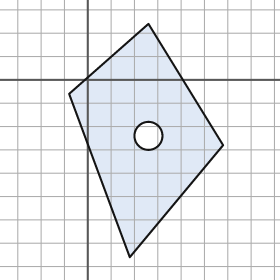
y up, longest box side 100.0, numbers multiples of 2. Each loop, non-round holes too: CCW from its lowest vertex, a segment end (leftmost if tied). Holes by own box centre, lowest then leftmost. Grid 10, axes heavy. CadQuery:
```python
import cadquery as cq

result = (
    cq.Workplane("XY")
    .moveTo(18.0, -76.0)
    .lineTo(58.0, -28.0)
    .lineTo(26.0, 24.0)
    .lineTo(-8.0, -6.0)
    .close()
    .moveTo(26.0, -24.0)
    .circle(6.0)
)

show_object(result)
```